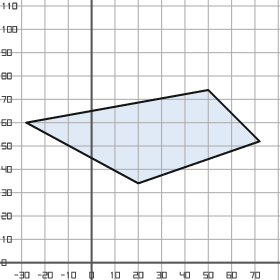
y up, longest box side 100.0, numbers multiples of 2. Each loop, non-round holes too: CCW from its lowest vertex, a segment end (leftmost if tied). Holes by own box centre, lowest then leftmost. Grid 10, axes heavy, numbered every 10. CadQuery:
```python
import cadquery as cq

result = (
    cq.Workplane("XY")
    .moveTo(20.0, 34.0)
    .lineTo(72.0, 52.0)
    .lineTo(50.0, 74.0)
    .lineTo(-28.0, 60.0)
    .close()
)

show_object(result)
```